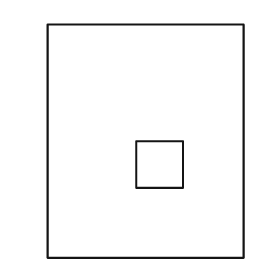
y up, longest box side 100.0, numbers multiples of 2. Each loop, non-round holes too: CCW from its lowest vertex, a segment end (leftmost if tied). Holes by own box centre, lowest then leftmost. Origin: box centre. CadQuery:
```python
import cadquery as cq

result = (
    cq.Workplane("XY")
    .moveTo(-42.0, -50.0)
    .lineTo(42.0, -50.0)
    .lineTo(42.0, 50.0)
    .lineTo(-42.0, 50.0)
    .close()
    .moveTo(-4.0, -20.0)
    .lineTo(16.0, -20.0)
    .lineTo(16.0, 0.0)
    .lineTo(-4.0, 0.0)
    .close()
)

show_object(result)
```